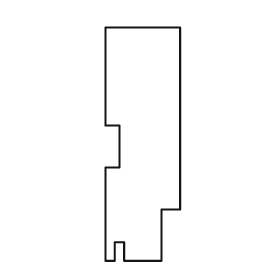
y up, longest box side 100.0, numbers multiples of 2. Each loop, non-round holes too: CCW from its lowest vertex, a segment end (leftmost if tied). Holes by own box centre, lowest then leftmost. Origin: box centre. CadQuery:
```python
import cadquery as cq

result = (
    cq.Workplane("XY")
    .moveTo(-16.0, -50.0)
    .lineTo(-12.0, -50.0)
    .lineTo(-12.0, -42.0)
    .lineTo(-8.0, -42.0)
    .lineTo(-8.0, -50.0)
    .lineTo(8.0, -50.0)
    .lineTo(8.0, -28.0)
    .lineTo(16.0, -28.0)
    .lineTo(16.0, 50.0)
    .lineTo(-16.0, 50.0)
    .lineTo(-16.0, 8.0)
    .lineTo(-10.0, 8.0)
    .lineTo(-10.0, -10.0)
    .lineTo(-16.0, -10.0)
    .close()
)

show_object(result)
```